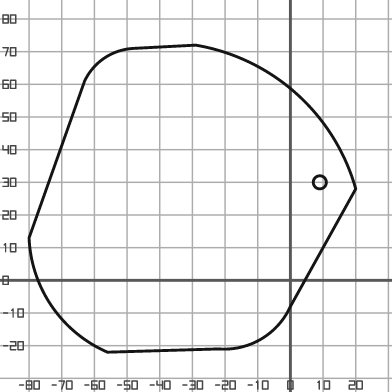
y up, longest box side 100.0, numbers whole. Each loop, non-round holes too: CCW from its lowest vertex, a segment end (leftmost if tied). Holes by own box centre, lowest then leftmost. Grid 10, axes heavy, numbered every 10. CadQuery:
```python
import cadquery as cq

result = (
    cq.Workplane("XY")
    .moveTo(-56.0, -22.0)
    .lineTo(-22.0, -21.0)
    .threePointArc((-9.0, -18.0), (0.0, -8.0))
    .lineTo(20.0, 28.0)
    .threePointArc((2.0, 57.0), (-29.0, 72.0))
    .lineTo(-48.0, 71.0)
    .threePointArc((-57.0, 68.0), (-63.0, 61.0))
    .lineTo(-80.0, 13.0)
    .threePointArc((-73.0, -8.0), (-56.0, -22.0))
    .close()
    .moveTo(9.0, 30.0)
    .circle(2.0)
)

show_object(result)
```